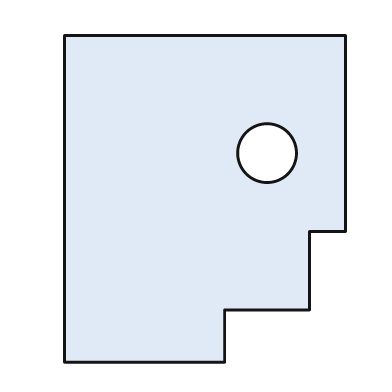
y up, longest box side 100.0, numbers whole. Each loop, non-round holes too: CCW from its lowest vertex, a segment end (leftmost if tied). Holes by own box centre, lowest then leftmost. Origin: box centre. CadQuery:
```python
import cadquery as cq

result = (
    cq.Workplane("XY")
    .moveTo(-43.0, -50.0)
    .lineTo(6.0, -50.0)
    .lineTo(6.0, -34.0)
    .lineTo(32.0, -34.0)
    .lineTo(32.0, -10.0)
    .lineTo(43.0, -10.0)
    .lineTo(43.0, 50.0)
    .lineTo(-43.0, 50.0)
    .close()
    .moveTo(19.0, 14.0)
    .circle(9.0)
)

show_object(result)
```